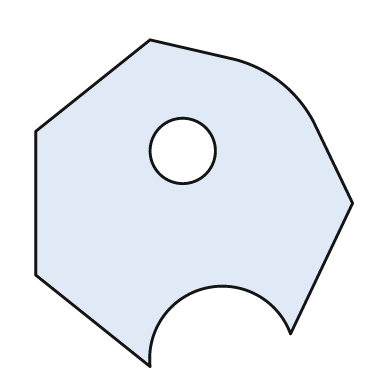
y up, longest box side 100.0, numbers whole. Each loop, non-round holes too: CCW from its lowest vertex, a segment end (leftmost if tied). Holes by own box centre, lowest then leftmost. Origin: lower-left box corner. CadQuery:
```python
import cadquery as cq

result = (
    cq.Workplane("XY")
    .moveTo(35.0, 0.0)
    .threePointArc((52.0, 24.0), (78.0, 10.0))
    .lineTo(97.0, 50.0)
    .lineTo(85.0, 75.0)
    .threePointArc((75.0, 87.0), (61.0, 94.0))
    .lineTo(35.0, 100.0)
    .lineTo(0.0, 72.0)
    .lineTo(0.0, 28.0)
    .close()
    .moveTo(45.0, 66.0)
    .circle(10.0)
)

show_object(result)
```